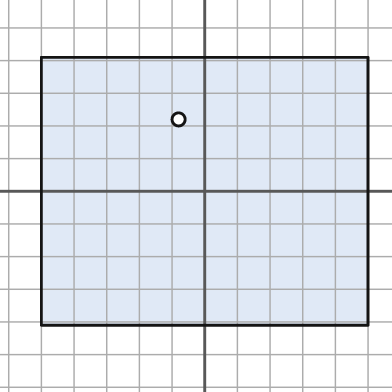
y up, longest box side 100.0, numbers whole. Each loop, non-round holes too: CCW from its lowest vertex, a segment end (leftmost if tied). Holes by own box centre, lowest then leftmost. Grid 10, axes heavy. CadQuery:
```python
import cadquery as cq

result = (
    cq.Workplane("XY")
    .moveTo(-50.0, -41.0)
    .lineTo(50.0, -41.0)
    .lineTo(50.0, 41.0)
    .lineTo(-50.0, 41.0)
    .close()
    .moveTo(-8.0, 22.0)
    .circle(2.0)
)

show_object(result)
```